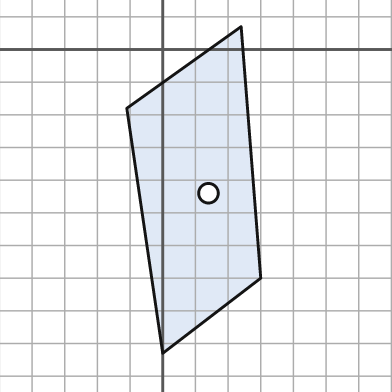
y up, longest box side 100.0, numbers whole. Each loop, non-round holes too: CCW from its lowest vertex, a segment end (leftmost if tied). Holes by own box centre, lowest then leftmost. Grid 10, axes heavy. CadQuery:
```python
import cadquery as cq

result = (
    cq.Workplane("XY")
    .moveTo(0.0, -93.0)
    .lineTo(30.0, -70.0)
    .lineTo(24.0, 7.0)
    .lineTo(-11.0, -18.0)
    .close()
    .moveTo(14.0, -44.0)
    .circle(3.0)
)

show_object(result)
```